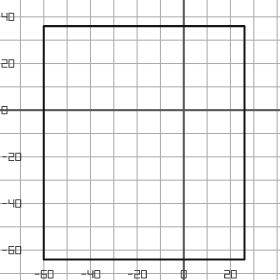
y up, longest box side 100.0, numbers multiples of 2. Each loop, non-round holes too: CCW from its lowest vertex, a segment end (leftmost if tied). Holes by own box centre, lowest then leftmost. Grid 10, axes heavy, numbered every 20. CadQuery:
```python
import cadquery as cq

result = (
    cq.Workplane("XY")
    .moveTo(-60.0, -64.0)
    .lineTo(26.0, -64.0)
    .lineTo(26.0, 36.0)
    .lineTo(-60.0, 36.0)
    .close()
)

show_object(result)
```